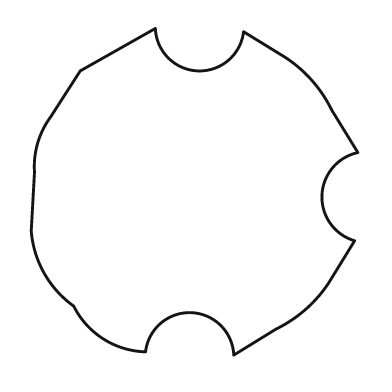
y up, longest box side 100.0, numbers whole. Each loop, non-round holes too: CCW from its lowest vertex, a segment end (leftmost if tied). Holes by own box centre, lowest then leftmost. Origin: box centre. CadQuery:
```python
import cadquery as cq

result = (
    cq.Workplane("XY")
    .moveTo(12.0, -50.0)
    .lineTo(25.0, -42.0)
    .threePointArc((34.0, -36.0), (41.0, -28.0))
    .lineTo(49.0, -15.0)
    .threePointArc((39.0, -1.0), (50.0, 12.0))
    .lineTo(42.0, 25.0)
    .threePointArc((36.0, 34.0), (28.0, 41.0))
    .lineTo(15.0, 49.0)
    .threePointArc((1.0, 37.0), (-12.0, 50.0))
    .lineTo(-35.0, 37.0)
    .lineTo(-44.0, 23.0)
    .threePointArc((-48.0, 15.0), (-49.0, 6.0))
    .lineTo(-50.0, -12.0)
    .threePointArc((-46.0, -25.0), (-37.0, -35.0))
    .threePointArc((-28.0, -45.0), (-15.0, -49.0))
    .threePointArc((-1.0, -37.0), (12.0, -50.0))
    .close()
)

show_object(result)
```